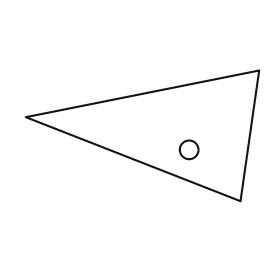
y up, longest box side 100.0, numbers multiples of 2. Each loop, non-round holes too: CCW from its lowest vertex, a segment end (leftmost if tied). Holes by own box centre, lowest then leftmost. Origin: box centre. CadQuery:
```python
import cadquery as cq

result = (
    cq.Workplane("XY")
    .moveTo(42.0, -28.0)
    .lineTo(50.0, 28.0)
    .lineTo(-50.0, 8.0)
    .close()
    .moveTo(20.0, -6.0)
    .circle(4.0)
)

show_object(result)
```